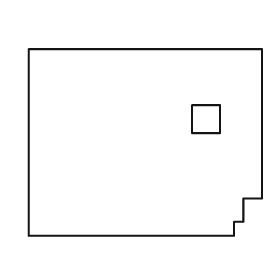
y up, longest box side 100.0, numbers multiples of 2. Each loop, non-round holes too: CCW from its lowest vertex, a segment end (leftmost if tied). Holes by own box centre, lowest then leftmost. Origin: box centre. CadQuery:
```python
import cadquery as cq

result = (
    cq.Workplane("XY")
    .moveTo(-50.0, -40.0)
    .lineTo(38.0, -40.0)
    .lineTo(38.0, -34.0)
    .lineTo(42.0, -34.0)
    .lineTo(42.0, -24.0)
    .lineTo(50.0, -24.0)
    .lineTo(50.0, 40.0)
    .lineTo(-50.0, 40.0)
    .close()
    .moveTo(20.0, 4.0)
    .lineTo(32.0, 4.0)
    .lineTo(32.0, 16.0)
    .lineTo(20.0, 16.0)
    .close()
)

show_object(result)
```